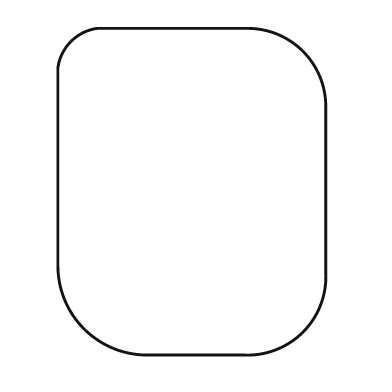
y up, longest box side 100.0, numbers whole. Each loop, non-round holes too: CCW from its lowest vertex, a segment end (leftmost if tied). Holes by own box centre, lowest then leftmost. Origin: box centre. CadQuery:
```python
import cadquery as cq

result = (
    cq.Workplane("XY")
    .moveTo(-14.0, -50.0)
    .lineTo(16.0, -50.0)
    .threePointArc((34.0, -43.0), (41.0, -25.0))
    .lineTo(41.0, 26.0)
    .threePointArc((34.0, 43.0), (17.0, 50.0))
    .lineTo(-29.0, 50.0)
    .threePointArc((-37.0, 46.0), (-41.0, 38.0))
    .lineTo(-41.0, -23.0)
    .threePointArc((-33.0, -42.0), (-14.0, -50.0))
    .close()
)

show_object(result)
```